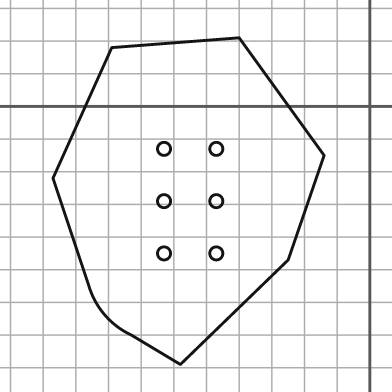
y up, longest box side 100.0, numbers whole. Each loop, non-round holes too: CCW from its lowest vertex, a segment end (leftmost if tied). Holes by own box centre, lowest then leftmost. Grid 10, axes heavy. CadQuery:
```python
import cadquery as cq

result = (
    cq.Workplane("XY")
    .moveTo(-58.0, -79.0)
    .lineTo(-25.0, -47.0)
    .lineTo(-14.0, -15.0)
    .lineTo(-40.0, 21.0)
    .lineTo(-79.0, 18.0)
    .lineTo(-97.0, -22.0)
    .lineTo(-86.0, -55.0)
    .threePointArc((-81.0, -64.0), (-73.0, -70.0))
    .close()
    .moveTo(-63.0, -45.0)
    .circle(2.0)
    .moveTo(-47.0, -45.0)
    .circle(2.0)
    .moveTo(-63.0, -29.0)
    .circle(2.0)
    .moveTo(-47.0, -29.0)
    .circle(2.0)
    .moveTo(-63.0, -13.0)
    .circle(2.0)
    .moveTo(-47.0, -13.0)
    .circle(2.0)
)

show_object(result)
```